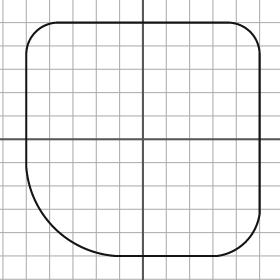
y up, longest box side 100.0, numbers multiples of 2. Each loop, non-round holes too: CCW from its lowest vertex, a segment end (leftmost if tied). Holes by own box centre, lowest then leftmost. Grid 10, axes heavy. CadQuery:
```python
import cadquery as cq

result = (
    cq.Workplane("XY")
    .moveTo(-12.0, -50.0)
    .lineTo(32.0, -50.0)
    .threePointArc((44.0, -44.0), (50.0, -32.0))
    .lineTo(50.0, 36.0)
    .threePointArc((46.0, 46.0), (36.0, 50.0))
    .lineTo(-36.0, 50.0)
    .threePointArc((-46.0, 46.0), (-50.0, 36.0))
    .lineTo(-50.0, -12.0)
    .threePointArc((-38.0, -38.0), (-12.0, -50.0))
    .close()
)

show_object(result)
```